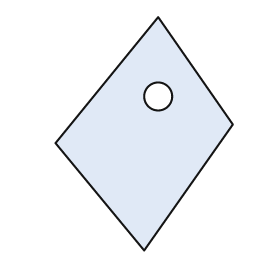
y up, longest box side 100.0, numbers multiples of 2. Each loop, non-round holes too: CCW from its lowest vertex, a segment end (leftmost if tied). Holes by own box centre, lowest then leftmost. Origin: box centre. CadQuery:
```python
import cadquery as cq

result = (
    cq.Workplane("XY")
    .moveTo(0.0, -50.0)
    .lineTo(38.0, 4.0)
    .lineTo(6.0, 50.0)
    .lineTo(-38.0, -4.0)
    .close()
    .moveTo(6.0, 16.0)
    .circle(6.0)
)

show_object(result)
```